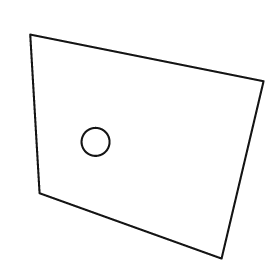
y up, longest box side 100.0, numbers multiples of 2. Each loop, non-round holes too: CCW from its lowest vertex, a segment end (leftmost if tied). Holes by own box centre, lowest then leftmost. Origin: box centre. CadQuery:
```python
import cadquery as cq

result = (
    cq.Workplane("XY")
    .moveTo(32.0, -48.0)
    .lineTo(50.0, 28.0)
    .lineTo(-50.0, 48.0)
    .lineTo(-46.0, -20.0)
    .close()
    .moveTo(-22.0, 2.0)
    .circle(6.0)
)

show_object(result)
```